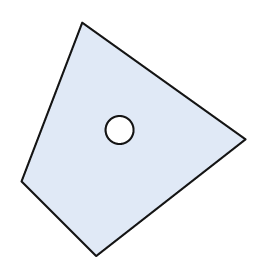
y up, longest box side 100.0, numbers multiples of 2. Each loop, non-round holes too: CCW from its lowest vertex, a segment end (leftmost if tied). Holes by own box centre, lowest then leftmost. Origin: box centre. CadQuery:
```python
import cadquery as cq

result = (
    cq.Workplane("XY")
    .moveTo(-16.0, -50.0)
    .lineTo(48.0, 0.0)
    .lineTo(-22.0, 50.0)
    .lineTo(-48.0, -18.0)
    .close()
    .moveTo(-6.0, 4.0)
    .circle(6.0)
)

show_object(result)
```